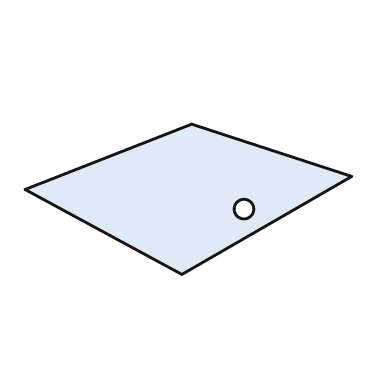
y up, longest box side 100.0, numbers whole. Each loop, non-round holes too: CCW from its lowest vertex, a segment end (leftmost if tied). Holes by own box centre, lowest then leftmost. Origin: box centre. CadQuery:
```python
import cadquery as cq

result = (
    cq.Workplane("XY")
    .moveTo(-2.0, -23.0)
    .lineTo(50.0, 7.0)
    .lineTo(1.0, 23.0)
    .lineTo(-50.0, 3.0)
    .close()
    .moveTo(17.0, -3.0)
    .circle(3.0)
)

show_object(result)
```